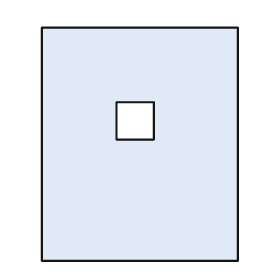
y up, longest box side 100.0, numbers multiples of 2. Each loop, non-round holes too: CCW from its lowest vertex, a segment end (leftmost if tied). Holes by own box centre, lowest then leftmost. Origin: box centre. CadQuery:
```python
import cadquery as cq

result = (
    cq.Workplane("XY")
    .moveTo(-42.0, -50.0)
    .lineTo(42.0, -50.0)
    .lineTo(42.0, 50.0)
    .lineTo(-42.0, 50.0)
    .close()
    .moveTo(-10.0, 2.0)
    .lineTo(6.0, 2.0)
    .lineTo(6.0, 18.0)
    .lineTo(-10.0, 18.0)
    .close()
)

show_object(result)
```